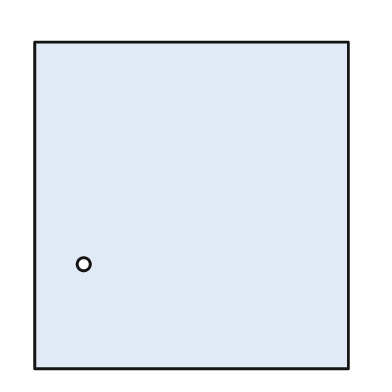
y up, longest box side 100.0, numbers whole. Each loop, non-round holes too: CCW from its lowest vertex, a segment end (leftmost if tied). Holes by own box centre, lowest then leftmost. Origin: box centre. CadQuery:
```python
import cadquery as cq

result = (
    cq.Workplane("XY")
    .moveTo(-48.0, -50.0)
    .lineTo(48.0, -50.0)
    .lineTo(48.0, 50.0)
    .lineTo(-48.0, 50.0)
    .close()
    .moveTo(-33.0, -18.0)
    .circle(2.0)
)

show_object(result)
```